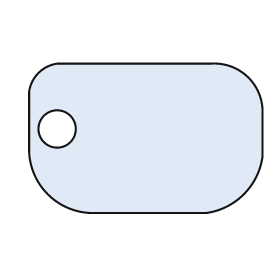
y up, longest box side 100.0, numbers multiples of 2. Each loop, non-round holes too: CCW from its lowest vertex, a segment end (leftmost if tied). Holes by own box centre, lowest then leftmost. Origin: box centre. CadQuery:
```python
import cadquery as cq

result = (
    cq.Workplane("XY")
    .moveTo(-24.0, -32.0)
    .lineTo(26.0, -32.0)
    .threePointArc((42.0, -24.0), (50.0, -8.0))
    .lineTo(50.0, 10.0)
    .threePointArc((44.0, 26.0), (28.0, 32.0))
    .lineTo(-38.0, 32.0)
    .threePointArc((-46.0, 28.0), (-50.0, 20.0))
    .lineTo(-50.0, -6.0)
    .threePointArc((-42.0, -24.0), (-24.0, -32.0))
    .close()
    .moveTo(-38.0, 4.0)
    .circle(8.0)
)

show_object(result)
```